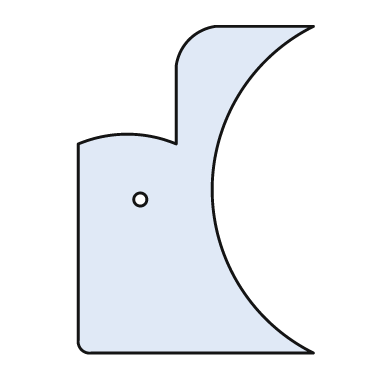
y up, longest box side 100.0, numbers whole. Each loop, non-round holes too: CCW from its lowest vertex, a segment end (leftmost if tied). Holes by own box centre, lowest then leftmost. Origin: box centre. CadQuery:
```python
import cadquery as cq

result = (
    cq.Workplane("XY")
    .moveTo(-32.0, -50.0)
    .lineTo(36.0, -50.0)
    .threePointArc((5.0, 0.0), (36.0, 50.0))
    .lineTo(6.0, 50.0)
    .threePointArc((-2.0, 46.0), (-6.0, 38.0))
    .lineTo(-6.0, 14.0)
    .threePointArc((-21.0, 17.0), (-36.0, 14.0))
    .lineTo(-36.0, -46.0)
    .threePointArc((-35.0, -49.0), (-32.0, -50.0))
    .close()
    .moveTo(-17.0, -3.0)
    .circle(2.0)
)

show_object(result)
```